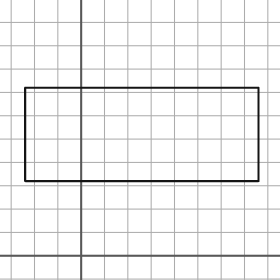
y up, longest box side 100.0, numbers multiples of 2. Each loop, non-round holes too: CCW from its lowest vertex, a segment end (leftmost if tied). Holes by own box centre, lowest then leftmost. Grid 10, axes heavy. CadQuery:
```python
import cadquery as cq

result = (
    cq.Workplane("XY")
    .moveTo(-24.0, 32.0)
    .lineTo(76.0, 32.0)
    .lineTo(76.0, 72.0)
    .lineTo(-24.0, 72.0)
    .close()
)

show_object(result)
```